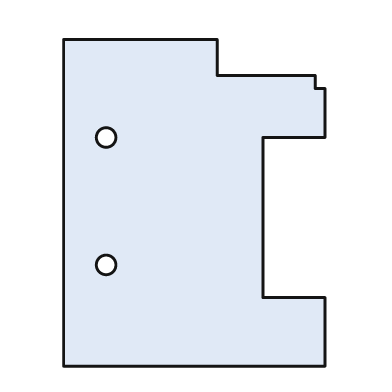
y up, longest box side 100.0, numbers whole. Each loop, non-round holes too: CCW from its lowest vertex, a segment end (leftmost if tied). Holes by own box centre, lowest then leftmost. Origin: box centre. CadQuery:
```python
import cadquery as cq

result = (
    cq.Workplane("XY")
    .moveTo(-40.0, -50.0)
    .lineTo(40.0, -50.0)
    .lineTo(40.0, -29.0)
    .lineTo(21.0, -29.0)
    .lineTo(21.0, 20.0)
    .lineTo(40.0, 20.0)
    .lineTo(40.0, 35.0)
    .lineTo(37.0, 35.0)
    .lineTo(37.0, 39.0)
    .lineTo(7.0, 39.0)
    .lineTo(7.0, 50.0)
    .lineTo(-40.0, 50.0)
    .close()
    .moveTo(-27.0, -19.0)
    .circle(3.0)
    .moveTo(-27.0, 20.0)
    .circle(3.0)
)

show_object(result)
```